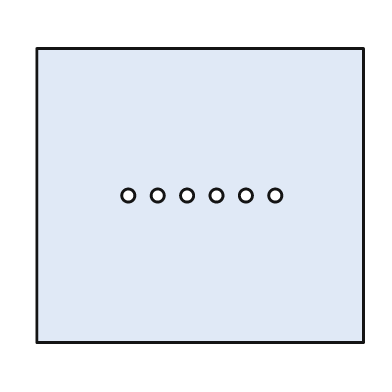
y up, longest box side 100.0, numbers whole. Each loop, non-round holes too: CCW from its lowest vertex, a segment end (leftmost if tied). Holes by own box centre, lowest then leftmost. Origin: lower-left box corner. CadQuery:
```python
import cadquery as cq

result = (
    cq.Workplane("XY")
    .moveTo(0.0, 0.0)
    .lineTo(100.0, 0.0)
    .lineTo(100.0, 90.0)
    .lineTo(0.0, 90.0)
    .close()
    .moveTo(28.0, 45.0)
    .circle(2.0)
    .moveTo(37.0, 45.0)
    .circle(2.0)
    .moveTo(46.0, 45.0)
    .circle(2.0)
    .moveTo(55.0, 45.0)
    .circle(2.0)
    .moveTo(64.0, 45.0)
    .circle(2.0)
    .moveTo(73.0, 45.0)
    .circle(2.0)
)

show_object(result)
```